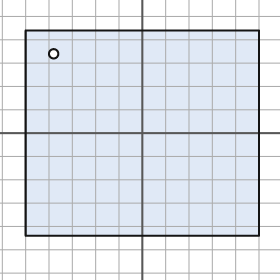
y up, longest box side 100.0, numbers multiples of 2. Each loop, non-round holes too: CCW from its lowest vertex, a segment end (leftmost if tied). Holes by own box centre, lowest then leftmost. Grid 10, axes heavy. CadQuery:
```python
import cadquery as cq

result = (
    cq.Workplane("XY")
    .moveTo(-50.0, -44.0)
    .lineTo(50.0, -44.0)
    .lineTo(50.0, 44.0)
    .lineTo(-50.0, 44.0)
    .close()
    .moveTo(-38.0, 34.0)
    .circle(2.0)
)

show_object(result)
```